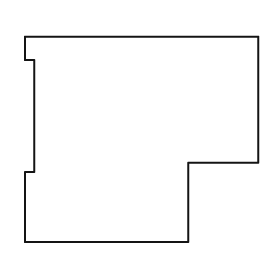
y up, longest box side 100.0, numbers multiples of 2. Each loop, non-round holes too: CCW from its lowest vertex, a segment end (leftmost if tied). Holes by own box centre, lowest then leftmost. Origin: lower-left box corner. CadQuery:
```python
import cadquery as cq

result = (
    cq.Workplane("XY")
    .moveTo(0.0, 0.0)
    .lineTo(70.0, 0.0)
    .lineTo(70.0, 34.0)
    .lineTo(100.0, 34.0)
    .lineTo(100.0, 88.0)
    .lineTo(0.0, 88.0)
    .lineTo(0.0, 78.0)
    .lineTo(4.0, 78.0)
    .lineTo(4.0, 30.0)
    .lineTo(0.0, 30.0)
    .close()
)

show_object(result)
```